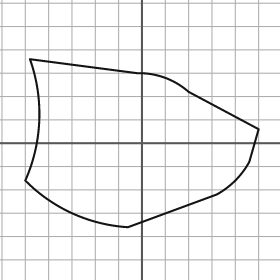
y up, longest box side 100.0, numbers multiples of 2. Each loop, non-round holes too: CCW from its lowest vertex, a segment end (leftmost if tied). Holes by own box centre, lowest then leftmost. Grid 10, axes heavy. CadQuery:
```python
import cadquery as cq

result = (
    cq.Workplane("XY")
    .moveTo(-6.0, -36.0)
    .lineTo(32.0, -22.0)
    .threePointArc((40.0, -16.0), (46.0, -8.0))
    .lineTo(50.0, 6.0)
    .lineTo(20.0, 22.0)
    .threePointArc((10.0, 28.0), (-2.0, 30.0))
    .lineTo(-48.0, 36.0)
    .threePointArc((-44.0, 10.0), (-50.0, -16.0))
    .threePointArc((-30.0, -30.0), (-6.0, -36.0))
    .close()
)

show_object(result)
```